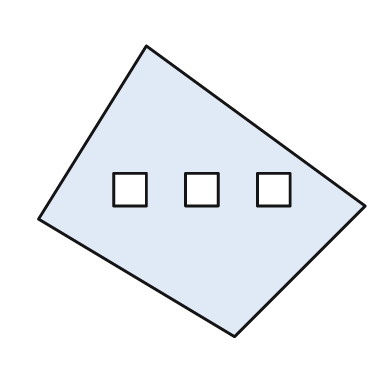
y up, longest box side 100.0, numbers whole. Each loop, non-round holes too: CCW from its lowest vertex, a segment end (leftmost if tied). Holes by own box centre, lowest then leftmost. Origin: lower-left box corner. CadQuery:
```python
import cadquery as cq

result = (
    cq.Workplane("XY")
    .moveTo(60.0, 0.0)
    .lineTo(100.0, 40.0)
    .lineTo(33.0, 89.0)
    .lineTo(0.0, 36.0)
    .close()
    .moveTo(23.0, 40.0)
    .lineTo(33.0, 40.0)
    .lineTo(33.0, 50.0)
    .lineTo(23.0, 50.0)
    .close()
    .moveTo(45.0, 40.0)
    .lineTo(55.0, 40.0)
    .lineTo(55.0, 50.0)
    .lineTo(45.0, 50.0)
    .close()
    .moveTo(67.0, 40.0)
    .lineTo(77.0, 40.0)
    .lineTo(77.0, 50.0)
    .lineTo(67.0, 50.0)
    .close()
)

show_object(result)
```